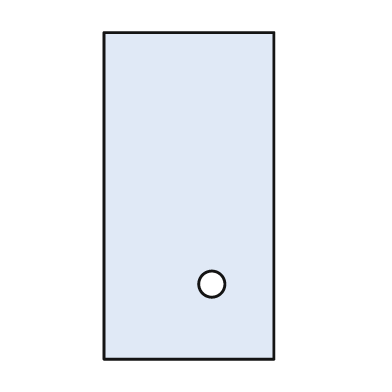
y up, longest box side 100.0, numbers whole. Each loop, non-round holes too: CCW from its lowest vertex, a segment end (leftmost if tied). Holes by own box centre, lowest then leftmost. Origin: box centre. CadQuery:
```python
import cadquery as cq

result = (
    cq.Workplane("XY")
    .moveTo(-26.0, -50.0)
    .lineTo(26.0, -50.0)
    .lineTo(26.0, 50.0)
    .lineTo(-26.0, 50.0)
    .close()
    .moveTo(7.0, -27.0)
    .circle(4.0)
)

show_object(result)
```